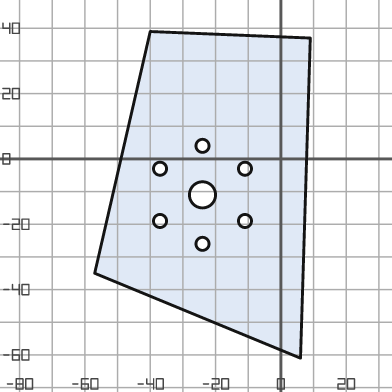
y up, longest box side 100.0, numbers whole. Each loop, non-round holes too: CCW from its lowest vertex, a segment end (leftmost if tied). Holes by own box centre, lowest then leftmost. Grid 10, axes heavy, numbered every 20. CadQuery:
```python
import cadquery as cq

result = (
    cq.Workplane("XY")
    .moveTo(6.0, -61.0)
    .lineTo(9.0, 37.0)
    .lineTo(-40.0, 39.0)
    .lineTo(-57.0, -35.0)
    .close()
    .moveTo(-24.0, -26.0)
    .circle(2.0)
    .moveTo(-37.0, -19.0)
    .circle(2.0)
    .moveTo(-11.0, -19.0)
    .circle(2.0)
    .moveTo(-24.0, -11.0)
    .circle(4.0)
    .moveTo(-37.0, -3.0)
    .circle(2.0)
    .moveTo(-11.0, -3.0)
    .circle(2.0)
    .moveTo(-24.0, 4.0)
    .circle(2.0)
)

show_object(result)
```